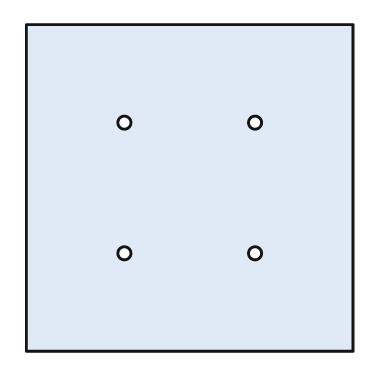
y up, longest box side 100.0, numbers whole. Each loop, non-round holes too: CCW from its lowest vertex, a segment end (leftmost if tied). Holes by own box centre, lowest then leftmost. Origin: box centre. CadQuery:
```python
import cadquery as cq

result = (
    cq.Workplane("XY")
    .moveTo(-50.0, -50.0)
    .lineTo(50.0, -50.0)
    .lineTo(50.0, 50.0)
    .lineTo(-50.0, 50.0)
    .close()
    .moveTo(-20.0, -20.0)
    .circle(2.0)
    .moveTo(20.0, -20.0)
    .circle(2.0)
    .moveTo(-20.0, 20.0)
    .circle(2.0)
    .moveTo(20.0, 20.0)
    .circle(2.0)
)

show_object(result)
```